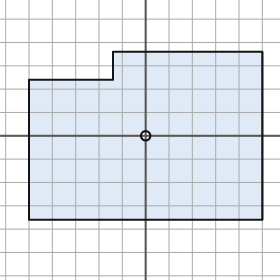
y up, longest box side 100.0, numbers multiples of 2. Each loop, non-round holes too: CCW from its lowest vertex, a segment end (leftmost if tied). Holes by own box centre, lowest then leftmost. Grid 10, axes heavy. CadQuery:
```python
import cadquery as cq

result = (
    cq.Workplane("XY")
    .moveTo(-50.0, -36.0)
    .lineTo(50.0, -36.0)
    .lineTo(50.0, 36.0)
    .lineTo(-14.0, 36.0)
    .lineTo(-14.0, 24.0)
    .lineTo(-50.0, 24.0)
    .close()
    .moveTo(0.0, 0.0)
    .circle(2.0)
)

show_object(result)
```